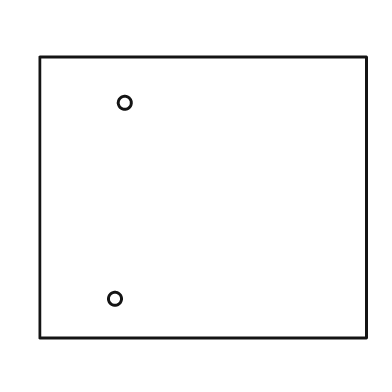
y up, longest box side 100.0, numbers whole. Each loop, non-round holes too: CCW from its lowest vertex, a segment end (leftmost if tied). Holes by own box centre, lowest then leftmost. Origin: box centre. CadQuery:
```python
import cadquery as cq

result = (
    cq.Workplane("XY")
    .moveTo(-50.0, -43.0)
    .lineTo(50.0, -43.0)
    .lineTo(50.0, 43.0)
    .lineTo(-50.0, 43.0)
    .close()
    .moveTo(-27.0, -31.0)
    .circle(2.0)
    .moveTo(-24.0, 29.0)
    .circle(2.0)
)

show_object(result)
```